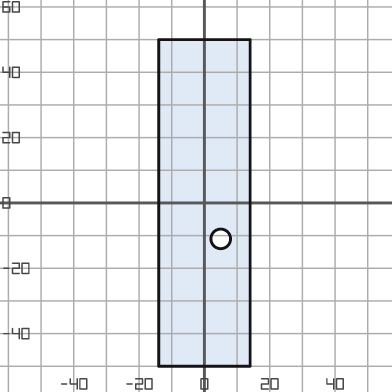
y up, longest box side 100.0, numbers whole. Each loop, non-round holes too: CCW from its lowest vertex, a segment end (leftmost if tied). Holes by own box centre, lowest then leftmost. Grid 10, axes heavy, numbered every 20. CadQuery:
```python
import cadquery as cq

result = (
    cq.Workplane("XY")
    .moveTo(-14.0, -50.0)
    .lineTo(14.0, -50.0)
    .lineTo(14.0, 50.0)
    .lineTo(-14.0, 50.0)
    .close()
    .moveTo(5.0, -11.0)
    .circle(3.0)
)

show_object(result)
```